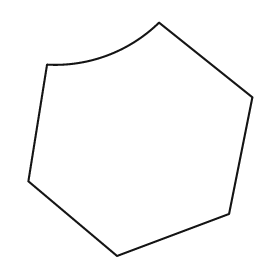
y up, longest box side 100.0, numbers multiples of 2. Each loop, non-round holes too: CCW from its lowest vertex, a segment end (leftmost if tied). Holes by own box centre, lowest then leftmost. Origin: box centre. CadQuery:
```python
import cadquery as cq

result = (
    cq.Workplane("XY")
    .moveTo(-10.0, -50.0)
    .lineTo(38.0, -32.0)
    .lineTo(48.0, 18.0)
    .lineTo(8.0, 50.0)
    .threePointArc((-14.0, 36.0), (-40.0, 32.0))
    .lineTo(-48.0, -18.0)
    .close()
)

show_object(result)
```